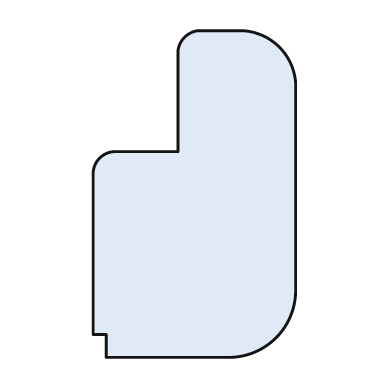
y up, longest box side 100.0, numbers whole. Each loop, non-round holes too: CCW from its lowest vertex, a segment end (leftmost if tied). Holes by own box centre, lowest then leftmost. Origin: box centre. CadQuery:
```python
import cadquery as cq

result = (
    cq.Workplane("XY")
    .moveTo(-27.0, -50.0)
    .lineTo(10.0, -50.0)
    .threePointArc((25.0, -44.0), (31.0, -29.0))
    .lineTo(31.0, 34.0)
    .threePointArc((26.0, 45.0), (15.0, 50.0))
    .lineTo(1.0, 50.0)
    .threePointArc((-3.0, 48.0), (-5.0, 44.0))
    .lineTo(-5.0, 13.0)
    .lineTo(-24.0, 13.0)
    .threePointArc((-29.0, 11.0), (-31.0, 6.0))
    .lineTo(-31.0, -43.0)
    .lineTo(-27.0, -43.0)
    .close()
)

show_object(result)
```